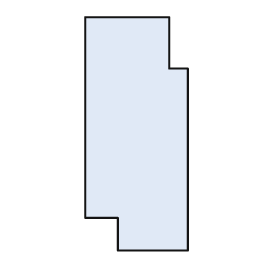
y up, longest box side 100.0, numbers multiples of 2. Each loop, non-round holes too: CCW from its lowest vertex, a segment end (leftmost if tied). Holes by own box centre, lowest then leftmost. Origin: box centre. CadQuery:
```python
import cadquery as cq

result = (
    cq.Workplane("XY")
    .moveTo(-8.0, -50.0)
    .lineTo(22.0, -50.0)
    .lineTo(22.0, 28.0)
    .lineTo(14.0, 28.0)
    .lineTo(14.0, 50.0)
    .lineTo(-22.0, 50.0)
    .lineTo(-22.0, -36.0)
    .lineTo(-8.0, -36.0)
    .close()
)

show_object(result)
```